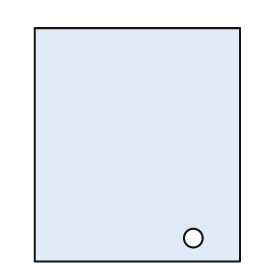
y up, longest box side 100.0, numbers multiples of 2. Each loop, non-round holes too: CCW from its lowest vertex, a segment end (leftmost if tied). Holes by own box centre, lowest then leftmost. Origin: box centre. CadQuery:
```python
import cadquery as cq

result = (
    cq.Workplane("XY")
    .moveTo(-44.0, -50.0)
    .lineTo(44.0, -50.0)
    .lineTo(44.0, 50.0)
    .lineTo(-44.0, 50.0)
    .close()
    .moveTo(24.0, -40.0)
    .circle(4.0)
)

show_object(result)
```